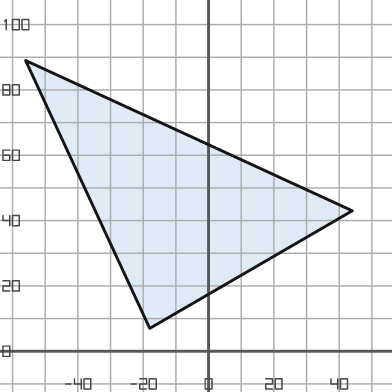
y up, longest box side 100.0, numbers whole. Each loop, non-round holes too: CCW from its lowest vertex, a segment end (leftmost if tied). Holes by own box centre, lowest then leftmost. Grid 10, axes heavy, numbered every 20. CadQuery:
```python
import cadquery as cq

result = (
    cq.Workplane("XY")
    .moveTo(-18.0, 7.0)
    .lineTo(44.0, 43.0)
    .lineTo(-56.0, 89.0)
    .close()
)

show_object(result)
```